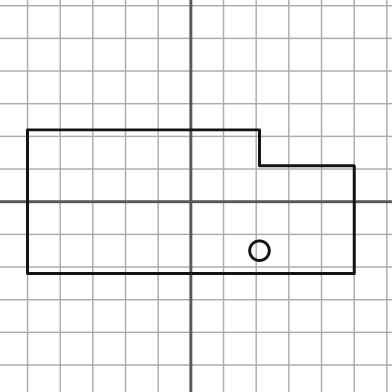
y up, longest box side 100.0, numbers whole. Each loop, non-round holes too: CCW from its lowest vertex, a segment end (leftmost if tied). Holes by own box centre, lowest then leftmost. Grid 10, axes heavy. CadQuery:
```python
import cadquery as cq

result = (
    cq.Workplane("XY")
    .moveTo(-50.0, -22.0)
    .lineTo(50.0, -22.0)
    .lineTo(50.0, 11.0)
    .lineTo(21.0, 11.0)
    .lineTo(21.0, 22.0)
    .lineTo(-50.0, 22.0)
    .close()
    .moveTo(21.0, -15.0)
    .circle(3.0)
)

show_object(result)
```